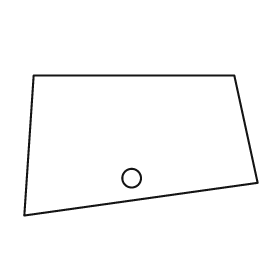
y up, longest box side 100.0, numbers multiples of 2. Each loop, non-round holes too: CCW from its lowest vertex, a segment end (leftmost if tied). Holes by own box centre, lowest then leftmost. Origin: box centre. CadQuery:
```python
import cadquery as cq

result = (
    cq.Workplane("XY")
    .moveTo(-50.0, -30.0)
    .lineTo(50.0, -16.0)
    .lineTo(40.0, 30.0)
    .lineTo(-46.0, 30.0)
    .close()
    .moveTo(-4.0, -14.0)
    .circle(4.0)
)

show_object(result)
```